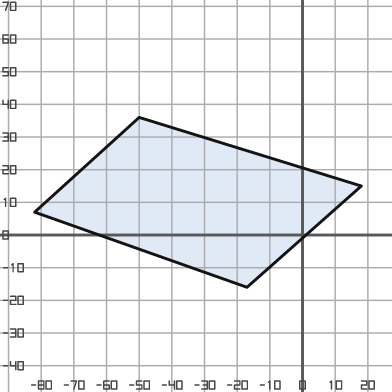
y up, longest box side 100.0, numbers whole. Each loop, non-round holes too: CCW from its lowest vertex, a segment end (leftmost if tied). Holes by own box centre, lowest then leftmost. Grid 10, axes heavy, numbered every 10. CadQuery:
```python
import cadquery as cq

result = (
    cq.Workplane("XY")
    .moveTo(-17.0, -16.0)
    .lineTo(18.0, 15.0)
    .lineTo(-50.0, 36.0)
    .lineTo(-82.0, 7.0)
    .close()
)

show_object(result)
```